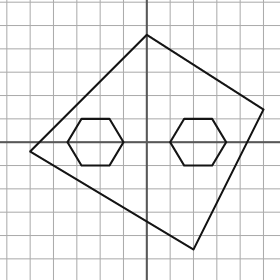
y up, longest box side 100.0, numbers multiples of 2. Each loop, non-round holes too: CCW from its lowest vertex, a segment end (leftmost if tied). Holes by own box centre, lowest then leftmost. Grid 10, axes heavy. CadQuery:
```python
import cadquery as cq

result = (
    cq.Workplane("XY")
    .moveTo(20.0, -46.0)
    .lineTo(50.0, 14.0)
    .lineTo(0.0, 46.0)
    .lineTo(-50.0, -4.0)
    .close()
    .moveTo(-28.0, -10.0)
    .lineTo(-16.0, -10.0)
    .lineTo(-10.0, 0.0)
    .lineTo(-16.0, 10.0)
    .lineTo(-28.0, 10.0)
    .lineTo(-34.0, 0.0)
    .close()
    .moveTo(16.0, -10.0)
    .lineTo(28.0, -10.0)
    .lineTo(34.0, 0.0)
    .lineTo(28.0, 10.0)
    .lineTo(16.0, 10.0)
    .lineTo(10.0, 0.0)
    .close()
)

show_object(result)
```